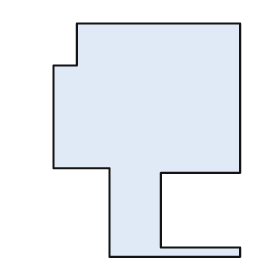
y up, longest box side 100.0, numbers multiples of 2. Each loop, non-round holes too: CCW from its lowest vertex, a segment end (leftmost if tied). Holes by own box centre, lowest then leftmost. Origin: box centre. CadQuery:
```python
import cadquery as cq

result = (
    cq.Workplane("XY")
    .moveTo(-16.0, -50.0)
    .lineTo(40.0, -50.0)
    .lineTo(40.0, -46.0)
    .lineTo(6.0, -46.0)
    .lineTo(6.0, -14.0)
    .lineTo(40.0, -14.0)
    .lineTo(40.0, 50.0)
    .lineTo(-30.0, 50.0)
    .lineTo(-30.0, 32.0)
    .lineTo(-40.0, 32.0)
    .lineTo(-40.0, -12.0)
    .lineTo(-16.0, -12.0)
    .close()
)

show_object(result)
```